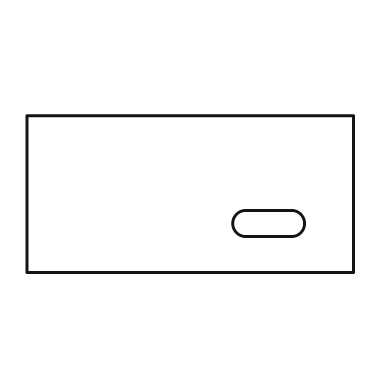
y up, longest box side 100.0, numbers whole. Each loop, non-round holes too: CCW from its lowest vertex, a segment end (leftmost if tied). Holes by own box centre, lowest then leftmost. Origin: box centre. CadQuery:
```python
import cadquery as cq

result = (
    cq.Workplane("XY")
    .moveTo(-50.0, -24.0)
    .lineTo(50.0, -24.0)
    .lineTo(50.0, 24.0)
    .lineTo(-50.0, 24.0)
    .close()
    .moveTo(17.0, -13.0)
    .lineTo(31.0, -13.0)
    .threePointArc((35.0, -9.0), (31.0, -5.0))
    .lineTo(17.0, -5.0)
    .threePointArc((13.0, -9.0), (17.0, -13.0))
    .close()
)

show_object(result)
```